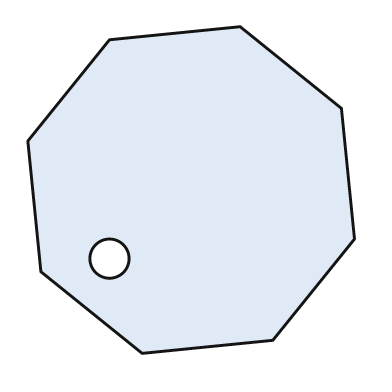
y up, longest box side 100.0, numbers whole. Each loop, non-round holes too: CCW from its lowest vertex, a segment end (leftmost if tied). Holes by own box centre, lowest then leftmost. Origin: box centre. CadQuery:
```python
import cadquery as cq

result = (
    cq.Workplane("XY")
    .moveTo(-15.0, -50.0)
    .lineTo(25.0, -46.0)
    .lineTo(50.0, -15.0)
    .lineTo(46.0, 25.0)
    .lineTo(15.0, 50.0)
    .lineTo(-25.0, 46.0)
    .lineTo(-50.0, 15.0)
    .lineTo(-46.0, -25.0)
    .close()
    .moveTo(-25.0, -21.0)
    .circle(6.0)
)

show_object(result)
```